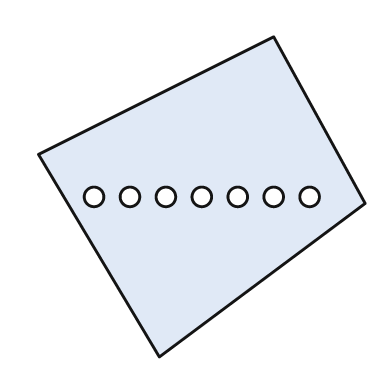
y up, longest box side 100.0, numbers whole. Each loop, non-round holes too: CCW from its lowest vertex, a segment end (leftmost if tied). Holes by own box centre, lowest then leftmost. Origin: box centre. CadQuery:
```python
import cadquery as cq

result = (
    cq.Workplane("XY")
    .moveTo(-13.0, -49.0)
    .lineTo(50.0, -2.0)
    .lineTo(22.0, 49.0)
    .lineTo(-50.0, 13.0)
    .close()
    .moveTo(-33.0, 0.0)
    .circle(3.0)
    .moveTo(-22.0, 0.0)
    .circle(3.0)
    .moveTo(-11.0, 0.0)
    .circle(3.0)
    .moveTo(0.0, 0.0)
    .circle(3.0)
    .moveTo(11.0, 0.0)
    .circle(3.0)
    .moveTo(22.0, 0.0)
    .circle(3.0)
    .moveTo(33.0, 0.0)
    .circle(3.0)
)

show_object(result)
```